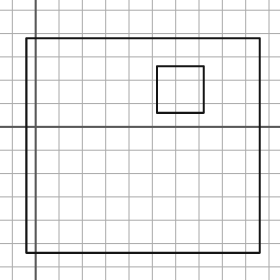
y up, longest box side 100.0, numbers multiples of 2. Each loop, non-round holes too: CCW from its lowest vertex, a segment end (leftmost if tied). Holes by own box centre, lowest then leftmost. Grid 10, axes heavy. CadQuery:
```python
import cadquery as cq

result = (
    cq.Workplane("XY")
    .moveTo(-4.0, -54.0)
    .lineTo(96.0, -54.0)
    .lineTo(96.0, 38.0)
    .lineTo(-4.0, 38.0)
    .close()
    .moveTo(52.0, 6.0)
    .lineTo(72.0, 6.0)
    .lineTo(72.0, 26.0)
    .lineTo(52.0, 26.0)
    .close()
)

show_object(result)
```